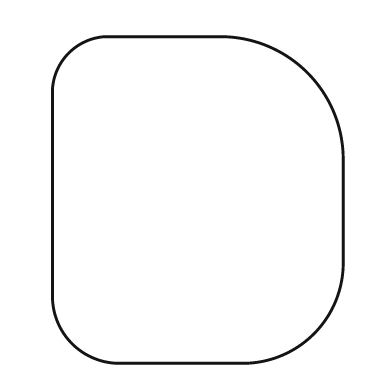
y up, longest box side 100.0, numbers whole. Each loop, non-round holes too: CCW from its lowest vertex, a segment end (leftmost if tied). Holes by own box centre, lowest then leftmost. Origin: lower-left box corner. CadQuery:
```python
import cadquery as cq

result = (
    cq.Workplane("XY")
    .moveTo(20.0, 0.0)
    .lineTo(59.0, 0.0)
    .threePointArc((80.0, 9.0), (89.0, 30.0))
    .lineTo(89.0, 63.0)
    .threePointArc((78.0, 89.0), (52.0, 100.0))
    .lineTo(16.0, 100.0)
    .threePointArc((5.0, 95.0), (0.0, 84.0))
    .lineTo(0.0, 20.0)
    .threePointArc((6.0, 6.0), (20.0, 0.0))
    .close()
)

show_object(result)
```